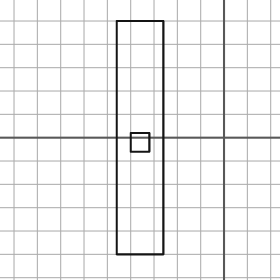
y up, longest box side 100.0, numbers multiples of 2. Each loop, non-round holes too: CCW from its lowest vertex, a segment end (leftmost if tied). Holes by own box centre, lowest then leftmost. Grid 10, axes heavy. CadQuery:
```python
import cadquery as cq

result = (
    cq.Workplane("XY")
    .moveTo(-46.0, -50.0)
    .lineTo(-26.0, -50.0)
    .lineTo(-26.0, 50.0)
    .lineTo(-46.0, 50.0)
    .close()
    .moveTo(-40.0, -6.0)
    .lineTo(-32.0, -6.0)
    .lineTo(-32.0, 2.0)
    .lineTo(-40.0, 2.0)
    .close()
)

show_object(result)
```